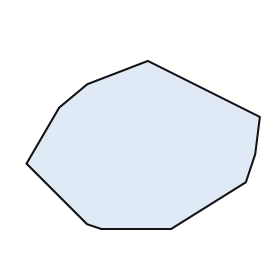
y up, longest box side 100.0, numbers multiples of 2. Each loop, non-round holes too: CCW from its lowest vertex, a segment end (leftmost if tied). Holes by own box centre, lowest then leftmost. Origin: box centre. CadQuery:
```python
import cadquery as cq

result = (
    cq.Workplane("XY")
    .moveTo(-18.0, -36.0)
    .lineTo(12.0, -36.0)
    .lineTo(44.0, -16.0)
    .lineTo(48.0, -4.0)
    .lineTo(50.0, 12.0)
    .lineTo(2.0, 36.0)
    .lineTo(-24.0, 26.0)
    .lineTo(-36.0, 16.0)
    .lineTo(-50.0, -8.0)
    .lineTo(-24.0, -34.0)
    .close()
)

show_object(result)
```